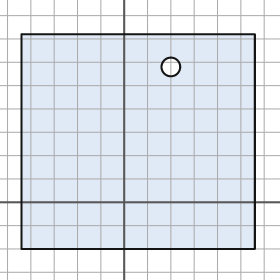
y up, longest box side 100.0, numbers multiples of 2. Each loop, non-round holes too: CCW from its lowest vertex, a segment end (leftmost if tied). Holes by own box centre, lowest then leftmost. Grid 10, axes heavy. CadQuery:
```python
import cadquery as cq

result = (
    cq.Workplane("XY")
    .moveTo(-44.0, -20.0)
    .lineTo(56.0, -20.0)
    .lineTo(56.0, 72.0)
    .lineTo(-44.0, 72.0)
    .close()
    .moveTo(20.0, 58.0)
    .circle(4.0)
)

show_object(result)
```